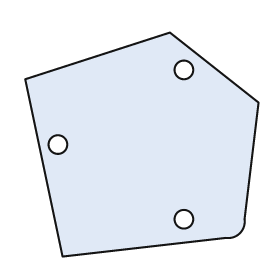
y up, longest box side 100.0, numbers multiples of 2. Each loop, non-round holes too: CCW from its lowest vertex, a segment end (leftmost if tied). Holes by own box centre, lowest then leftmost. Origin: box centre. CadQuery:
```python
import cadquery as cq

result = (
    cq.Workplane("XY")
    .moveTo(-34.0, -48.0)
    .lineTo(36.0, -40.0)
    .threePointArc((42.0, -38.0), (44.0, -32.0))
    .lineTo(50.0, 18.0)
    .lineTo(12.0, 48.0)
    .lineTo(-50.0, 28.0)
    .close()
    .moveTo(18.0, -32.0)
    .circle(4.0)
    .moveTo(-36.0, 0.0)
    .circle(4.0)
    .moveTo(18.0, 32.0)
    .circle(4.0)
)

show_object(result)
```